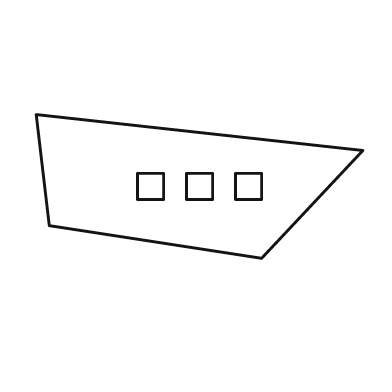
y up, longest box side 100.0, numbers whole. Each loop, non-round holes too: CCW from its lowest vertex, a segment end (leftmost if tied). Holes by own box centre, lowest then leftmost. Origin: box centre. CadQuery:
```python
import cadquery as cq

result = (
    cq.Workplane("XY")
    .moveTo(19.0, -22.0)
    .lineTo(50.0, 11.0)
    .lineTo(-50.0, 22.0)
    .lineTo(-46.0, -12.0)
    .close()
    .moveTo(-19.0, -4.0)
    .lineTo(-11.0, -4.0)
    .lineTo(-11.0, 4.0)
    .lineTo(-19.0, 4.0)
    .close()
    .moveTo(-4.0, -4.0)
    .lineTo(4.0, -4.0)
    .lineTo(4.0, 4.0)
    .lineTo(-4.0, 4.0)
    .close()
    .moveTo(11.0, -4.0)
    .lineTo(19.0, -4.0)
    .lineTo(19.0, 4.0)
    .lineTo(11.0, 4.0)
    .close()
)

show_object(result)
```